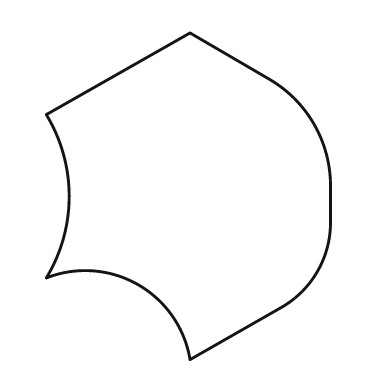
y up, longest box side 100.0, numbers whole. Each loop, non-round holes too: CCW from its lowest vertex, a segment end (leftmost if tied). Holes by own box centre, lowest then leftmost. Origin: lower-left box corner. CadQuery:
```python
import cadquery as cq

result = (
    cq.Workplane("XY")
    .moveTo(44.0, 0.0)
    .lineTo(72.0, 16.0)
    .threePointArc((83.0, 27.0), (87.0, 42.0))
    .lineTo(87.0, 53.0)
    .threePointArc((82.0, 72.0), (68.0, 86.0))
    .lineTo(44.0, 100.0)
    .lineTo(0.0, 75.0)
    .threePointArc((7.0, 50.0), (0.0, 25.0))
    .threePointArc((28.0, 23.0), (44.0, 0.0))
    .close()
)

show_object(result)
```